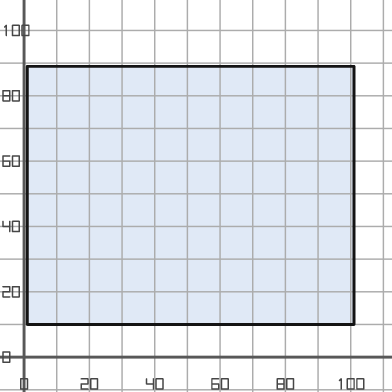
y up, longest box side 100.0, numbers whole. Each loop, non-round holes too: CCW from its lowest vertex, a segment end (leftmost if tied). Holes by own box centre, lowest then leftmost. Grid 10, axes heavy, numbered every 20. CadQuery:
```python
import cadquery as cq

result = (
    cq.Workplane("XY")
    .moveTo(1.0, 10.0)
    .lineTo(101.0, 10.0)
    .lineTo(101.0, 89.0)
    .lineTo(1.0, 89.0)
    .close()
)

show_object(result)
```